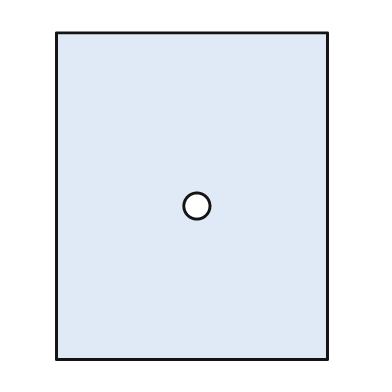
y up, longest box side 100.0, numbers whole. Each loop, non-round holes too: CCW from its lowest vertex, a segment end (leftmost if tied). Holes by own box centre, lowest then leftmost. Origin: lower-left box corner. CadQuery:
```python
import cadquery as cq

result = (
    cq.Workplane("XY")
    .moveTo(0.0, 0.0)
    .lineTo(83.0, 0.0)
    .lineTo(83.0, 100.0)
    .lineTo(0.0, 100.0)
    .close()
    .moveTo(43.0, 47.0)
    .circle(4.0)
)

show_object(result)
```